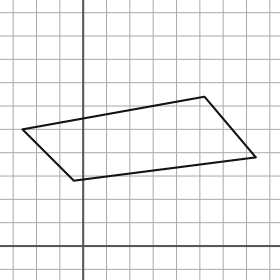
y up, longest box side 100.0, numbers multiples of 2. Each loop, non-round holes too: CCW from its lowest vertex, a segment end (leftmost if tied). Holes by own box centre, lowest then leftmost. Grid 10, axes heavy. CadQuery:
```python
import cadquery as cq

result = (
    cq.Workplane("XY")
    .moveTo(-4.0, 28.0)
    .lineTo(74.0, 38.0)
    .lineTo(52.0, 64.0)
    .lineTo(-26.0, 50.0)
    .close()
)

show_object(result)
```